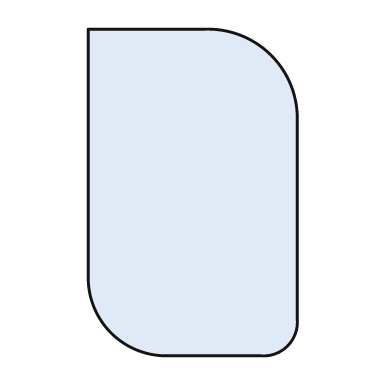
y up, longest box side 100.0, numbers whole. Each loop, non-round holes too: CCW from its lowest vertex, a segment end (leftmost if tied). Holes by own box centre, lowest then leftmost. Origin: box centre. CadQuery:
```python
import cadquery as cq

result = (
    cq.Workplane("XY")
    .moveTo(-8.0, -50.0)
    .lineTo(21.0, -50.0)
    .threePointArc((29.0, -47.0), (32.0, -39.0))
    .lineTo(32.0, 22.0)
    .threePointArc((24.0, 42.0), (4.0, 50.0))
    .lineTo(-32.0, 50.0)
    .lineTo(-32.0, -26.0)
    .threePointArc((-25.0, -43.0), (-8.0, -50.0))
    .close()
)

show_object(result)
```